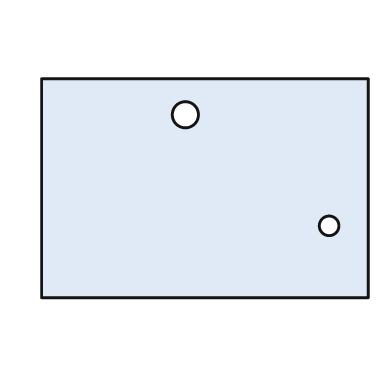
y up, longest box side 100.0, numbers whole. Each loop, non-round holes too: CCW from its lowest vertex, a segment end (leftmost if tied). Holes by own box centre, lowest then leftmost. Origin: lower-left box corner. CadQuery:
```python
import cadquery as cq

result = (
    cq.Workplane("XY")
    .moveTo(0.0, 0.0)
    .lineTo(100.0, 0.0)
    .lineTo(100.0, 67.0)
    .lineTo(0.0, 67.0)
    .close()
    .moveTo(88.0, 22.0)
    .circle(3.0)
    .moveTo(44.0, 56.0)
    .circle(4.0)
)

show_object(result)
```